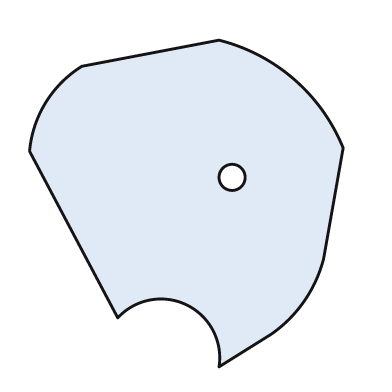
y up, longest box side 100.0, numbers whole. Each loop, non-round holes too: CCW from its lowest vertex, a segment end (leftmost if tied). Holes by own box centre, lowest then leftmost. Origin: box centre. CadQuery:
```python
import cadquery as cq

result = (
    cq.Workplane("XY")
    .moveTo(10.0, -50.0)
    .lineTo(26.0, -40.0)
    .threePointArc((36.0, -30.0), (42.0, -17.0))
    .lineTo(48.0, 17.0)
    .threePointArc((33.0, 38.0), (10.0, 50.0))
    .lineTo(-32.0, 42.0)
    .threePointArc((-43.0, 31.0), (-48.0, 16.0))
    .lineTo(-21.0, -35.0)
    .threePointArc((0.0, -31.0), (10.0, -50.0))
    .close()
    .moveTo(14.0, 8.0)
    .circle(4.0)
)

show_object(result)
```